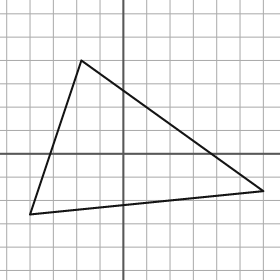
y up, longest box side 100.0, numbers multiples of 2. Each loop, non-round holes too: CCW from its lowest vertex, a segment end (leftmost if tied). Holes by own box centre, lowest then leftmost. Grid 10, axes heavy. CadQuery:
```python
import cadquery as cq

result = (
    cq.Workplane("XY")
    .moveTo(-40.0, -26.0)
    .lineTo(60.0, -16.0)
    .lineTo(-18.0, 40.0)
    .close()
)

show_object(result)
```